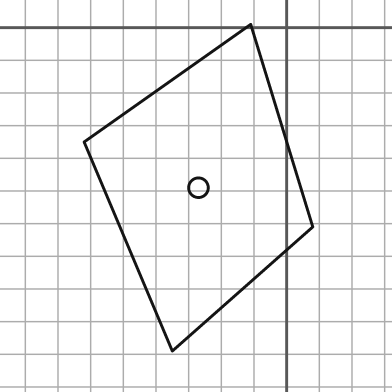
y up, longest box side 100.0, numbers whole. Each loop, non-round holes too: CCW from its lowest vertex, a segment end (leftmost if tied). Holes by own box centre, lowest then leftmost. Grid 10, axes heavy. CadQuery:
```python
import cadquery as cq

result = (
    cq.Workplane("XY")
    .moveTo(-35.0, -99.0)
    .lineTo(8.0, -61.0)
    .lineTo(-11.0, 1.0)
    .lineTo(-62.0, -35.0)
    .close()
    .moveTo(-27.0, -49.0)
    .circle(3.0)
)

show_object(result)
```